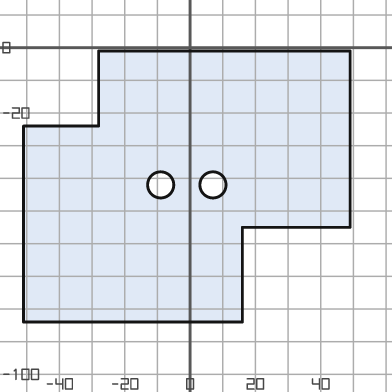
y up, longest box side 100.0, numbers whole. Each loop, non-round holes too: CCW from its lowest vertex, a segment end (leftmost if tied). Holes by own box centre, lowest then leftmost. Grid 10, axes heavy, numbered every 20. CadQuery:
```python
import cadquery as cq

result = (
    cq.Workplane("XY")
    .moveTo(-51.0, -84.0)
    .lineTo(16.0, -84.0)
    .lineTo(16.0, -55.0)
    .lineTo(49.0, -55.0)
    .lineTo(49.0, -1.0)
    .lineTo(-28.0, -1.0)
    .lineTo(-28.0, -24.0)
    .lineTo(-51.0, -24.0)
    .close()
    .moveTo(-9.0, -42.0)
    .circle(4.0)
    .moveTo(7.0, -42.0)
    .circle(4.0)
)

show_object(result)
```